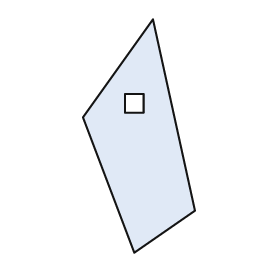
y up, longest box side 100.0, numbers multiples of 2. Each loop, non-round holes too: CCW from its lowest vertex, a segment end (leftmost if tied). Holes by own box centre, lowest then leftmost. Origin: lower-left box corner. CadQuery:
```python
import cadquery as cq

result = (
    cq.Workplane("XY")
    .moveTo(22.0, 0.0)
    .lineTo(48.0, 18.0)
    .lineTo(30.0, 100.0)
    .lineTo(0.0, 58.0)
    .close()
    .moveTo(18.0, 60.0)
    .lineTo(26.0, 60.0)
    .lineTo(26.0, 68.0)
    .lineTo(18.0, 68.0)
    .close()
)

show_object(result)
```